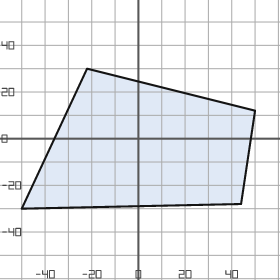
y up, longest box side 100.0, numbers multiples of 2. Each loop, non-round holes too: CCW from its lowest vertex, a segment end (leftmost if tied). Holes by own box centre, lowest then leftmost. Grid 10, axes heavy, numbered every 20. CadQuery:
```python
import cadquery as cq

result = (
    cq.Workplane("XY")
    .moveTo(-50.0, -30.0)
    .lineTo(44.0, -28.0)
    .lineTo(50.0, 12.0)
    .lineTo(-22.0, 30.0)
    .close()
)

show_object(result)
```